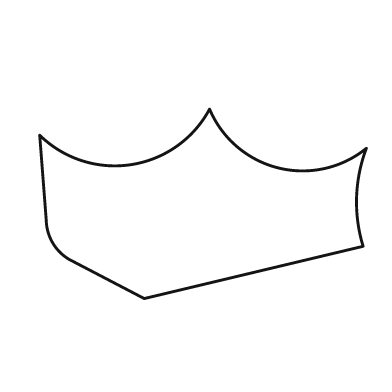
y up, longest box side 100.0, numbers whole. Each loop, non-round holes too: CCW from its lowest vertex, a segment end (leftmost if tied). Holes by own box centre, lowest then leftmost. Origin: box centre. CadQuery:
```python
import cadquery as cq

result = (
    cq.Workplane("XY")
    .moveTo(-18.0, -29.0)
    .lineTo(49.0, -13.0)
    .threePointArc((47.0, 2.0), (50.0, 17.0))
    .threePointArc((23.0, 11.0), (2.0, 29.0))
    .threePointArc((-22.0, 12.0), (-50.0, 21.0))
    .lineTo(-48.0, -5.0)
    .threePointArc((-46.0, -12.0), (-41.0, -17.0))
    .close()
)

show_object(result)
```